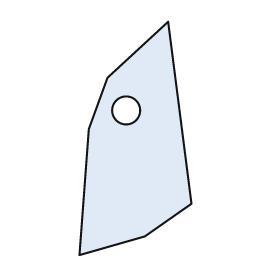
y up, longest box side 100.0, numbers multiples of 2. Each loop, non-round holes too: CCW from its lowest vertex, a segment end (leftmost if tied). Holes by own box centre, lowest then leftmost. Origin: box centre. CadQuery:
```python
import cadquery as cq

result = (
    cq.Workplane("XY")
    .moveTo(-24.0, -50.0)
    .lineTo(4.0, -42.0)
    .lineTo(24.0, -28.0)
    .lineTo(14.0, 50.0)
    .lineTo(-12.0, 26.0)
    .lineTo(-20.0, 4.0)
    .close()
    .moveTo(-4.0, 12.0)
    .circle(6.0)
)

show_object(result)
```